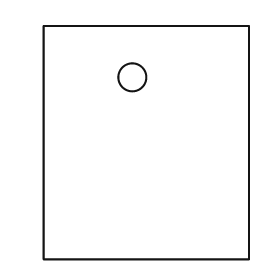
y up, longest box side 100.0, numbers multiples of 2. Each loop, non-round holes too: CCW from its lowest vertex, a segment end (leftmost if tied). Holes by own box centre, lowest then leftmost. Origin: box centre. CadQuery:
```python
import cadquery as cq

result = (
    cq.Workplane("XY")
    .moveTo(-44.0, -50.0)
    .lineTo(44.0, -50.0)
    .lineTo(44.0, 50.0)
    .lineTo(-44.0, 50.0)
    .close()
    .moveTo(-6.0, 28.0)
    .circle(6.0)
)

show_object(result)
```